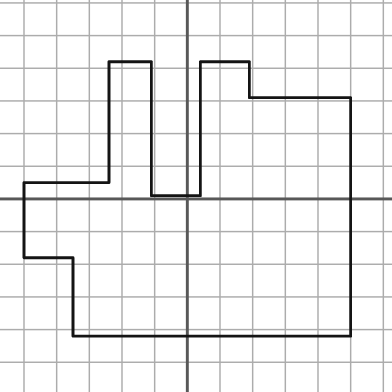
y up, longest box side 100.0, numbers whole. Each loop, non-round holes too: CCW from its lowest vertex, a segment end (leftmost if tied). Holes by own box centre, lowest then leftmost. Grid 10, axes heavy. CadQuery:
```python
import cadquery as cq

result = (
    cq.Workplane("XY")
    .moveTo(-35.0, -42.0)
    .lineTo(50.0, -42.0)
    .lineTo(50.0, 31.0)
    .lineTo(19.0, 31.0)
    .lineTo(19.0, 42.0)
    .lineTo(4.0, 42.0)
    .lineTo(4.0, 1.0)
    .lineTo(-11.0, 1.0)
    .lineTo(-11.0, 42.0)
    .lineTo(-24.0, 42.0)
    .lineTo(-24.0, 5.0)
    .lineTo(-50.0, 5.0)
    .lineTo(-50.0, -18.0)
    .lineTo(-35.0, -18.0)
    .close()
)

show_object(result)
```